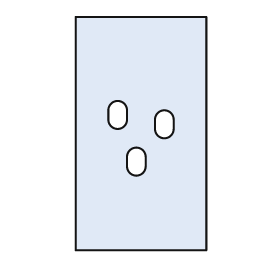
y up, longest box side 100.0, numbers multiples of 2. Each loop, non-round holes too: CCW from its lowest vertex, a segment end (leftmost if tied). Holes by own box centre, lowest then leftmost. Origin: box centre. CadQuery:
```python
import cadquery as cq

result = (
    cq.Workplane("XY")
    .moveTo(-28.0, -50.0)
    .lineTo(28.0, -50.0)
    .lineTo(28.0, 50.0)
    .lineTo(-28.0, 50.0)
    .close()
    .moveTo(-6.0, -14.0)
    .threePointArc((-2.0, -18.0), (2.0, -14.0))
    .lineTo(2.0, -10.0)
    .threePointArc((-2.0, -6.0), (-6.0, -10.0))
    .close()
    .moveTo(6.0, 2.0)
    .threePointArc((10.0, -2.0), (14.0, 2.0))
    .lineTo(14.0, 6.0)
    .threePointArc((10.0, 10.0), (6.0, 6.0))
    .close()
    .moveTo(-14.0, 6.0)
    .threePointArc((-10.0, 2.0), (-6.0, 6.0))
    .lineTo(-6.0, 10.0)
    .threePointArc((-10.0, 14.0), (-14.0, 10.0))
    .close()
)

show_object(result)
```